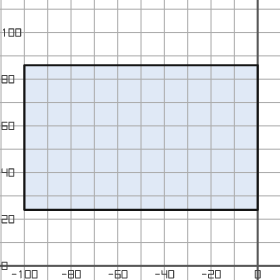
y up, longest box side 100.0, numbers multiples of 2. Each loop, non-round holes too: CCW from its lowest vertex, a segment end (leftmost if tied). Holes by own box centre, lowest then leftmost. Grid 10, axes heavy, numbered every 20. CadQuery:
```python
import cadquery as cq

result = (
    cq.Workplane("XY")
    .moveTo(-100.0, 24.0)
    .lineTo(0.0, 24.0)
    .lineTo(0.0, 86.0)
    .lineTo(-100.0, 86.0)
    .close()
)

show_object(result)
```